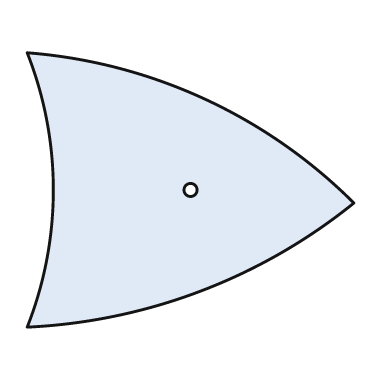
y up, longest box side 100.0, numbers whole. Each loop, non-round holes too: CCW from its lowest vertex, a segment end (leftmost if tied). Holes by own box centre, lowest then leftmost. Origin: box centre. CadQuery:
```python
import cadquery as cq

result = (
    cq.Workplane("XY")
    .moveTo(-50.0, -42.0)
    .threePointArc((3.0, -31.0), (50.0, -4.0))
    .threePointArc((4.0, 28.0), (-50.0, 42.0))
    .threePointArc((-42.0, 0.0), (-50.0, -42.0))
    .close()
    .moveTo(0.0, 0.0)
    .circle(2.0)
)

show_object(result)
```